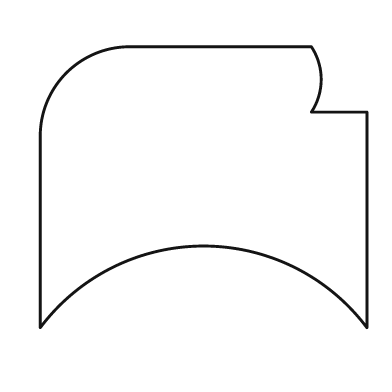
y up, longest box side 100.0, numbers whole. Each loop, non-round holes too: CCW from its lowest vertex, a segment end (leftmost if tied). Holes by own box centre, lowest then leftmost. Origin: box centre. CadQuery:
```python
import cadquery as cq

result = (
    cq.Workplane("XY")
    .moveTo(-50.0, -43.0)
    .threePointArc((0.0, -18.0), (50.0, -43.0))
    .lineTo(50.0, 23.0)
    .lineTo(33.0, 23.0)
    .threePointArc((36.0, 33.0), (33.0, 43.0))
    .lineTo(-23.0, 43.0)
    .threePointArc((-42.0, 35.0), (-50.0, 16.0))
    .close()
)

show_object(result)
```